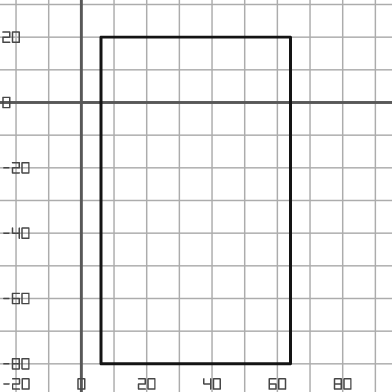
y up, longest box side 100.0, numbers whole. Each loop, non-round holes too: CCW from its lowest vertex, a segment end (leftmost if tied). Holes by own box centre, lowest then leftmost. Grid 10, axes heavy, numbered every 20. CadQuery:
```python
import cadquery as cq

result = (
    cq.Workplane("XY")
    .moveTo(6.0, -80.0)
    .lineTo(64.0, -80.0)
    .lineTo(64.0, 20.0)
    .lineTo(6.0, 20.0)
    .close()
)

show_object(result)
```